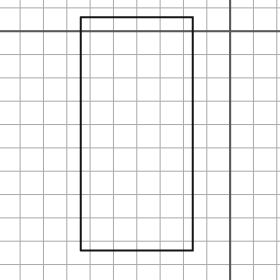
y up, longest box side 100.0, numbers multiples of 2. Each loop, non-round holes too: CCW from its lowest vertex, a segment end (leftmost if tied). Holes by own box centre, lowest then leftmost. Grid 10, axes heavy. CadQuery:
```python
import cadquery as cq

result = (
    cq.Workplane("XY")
    .moveTo(-64.0, -94.0)
    .lineTo(-16.0, -94.0)
    .lineTo(-16.0, 6.0)
    .lineTo(-64.0, 6.0)
    .close()
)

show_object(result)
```